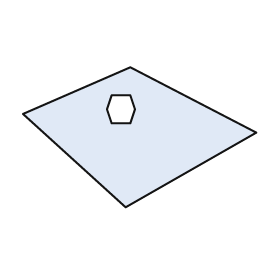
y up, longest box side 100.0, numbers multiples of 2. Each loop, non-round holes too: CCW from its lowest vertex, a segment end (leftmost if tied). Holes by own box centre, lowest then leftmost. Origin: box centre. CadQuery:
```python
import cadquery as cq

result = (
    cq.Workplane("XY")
    .moveTo(-6.0, -30.0)
    .lineTo(50.0, 2.0)
    .lineTo(-4.0, 30.0)
    .lineTo(-50.0, 10.0)
    .close()
    .moveTo(-12.0, 6.0)
    .lineTo(-4.0, 6.0)
    .lineTo(-2.0, 12.0)
    .lineTo(-4.0, 18.0)
    .lineTo(-12.0, 18.0)
    .lineTo(-14.0, 12.0)
    .close()
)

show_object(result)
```